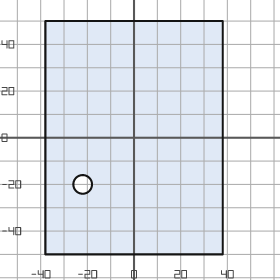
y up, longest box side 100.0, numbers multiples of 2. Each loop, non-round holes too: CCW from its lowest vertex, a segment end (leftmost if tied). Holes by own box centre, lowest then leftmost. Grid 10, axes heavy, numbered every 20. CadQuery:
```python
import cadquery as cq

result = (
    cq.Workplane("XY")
    .moveTo(-38.0, -50.0)
    .lineTo(38.0, -50.0)
    .lineTo(38.0, 50.0)
    .lineTo(-38.0, 50.0)
    .close()
    .moveTo(-22.0, -20.0)
    .circle(4.0)
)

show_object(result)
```